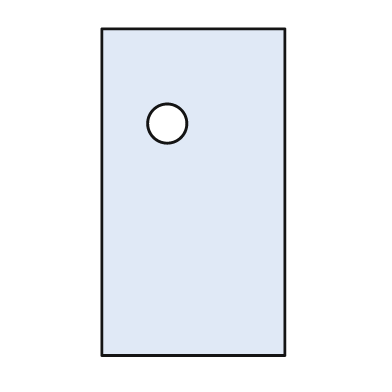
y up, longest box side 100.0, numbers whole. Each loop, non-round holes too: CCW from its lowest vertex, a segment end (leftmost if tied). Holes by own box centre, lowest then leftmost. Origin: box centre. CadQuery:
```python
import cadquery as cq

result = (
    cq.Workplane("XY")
    .moveTo(-28.0, -50.0)
    .lineTo(28.0, -50.0)
    .lineTo(28.0, 50.0)
    .lineTo(-28.0, 50.0)
    .close()
    .moveTo(-8.0, 21.0)
    .circle(6.0)
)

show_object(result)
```